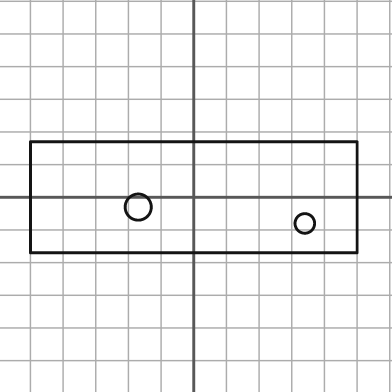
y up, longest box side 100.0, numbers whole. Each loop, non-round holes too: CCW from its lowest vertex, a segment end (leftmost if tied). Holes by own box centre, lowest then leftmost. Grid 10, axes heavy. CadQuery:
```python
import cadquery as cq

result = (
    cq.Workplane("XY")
    .moveTo(-50.0, -17.0)
    .lineTo(50.0, -17.0)
    .lineTo(50.0, 17.0)
    .lineTo(-50.0, 17.0)
    .close()
    .moveTo(34.0, -8.0)
    .circle(3.0)
    .moveTo(-17.0, -3.0)
    .circle(4.0)
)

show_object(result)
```